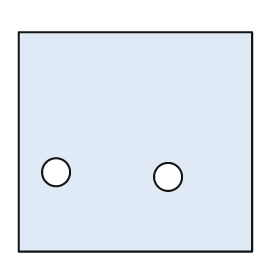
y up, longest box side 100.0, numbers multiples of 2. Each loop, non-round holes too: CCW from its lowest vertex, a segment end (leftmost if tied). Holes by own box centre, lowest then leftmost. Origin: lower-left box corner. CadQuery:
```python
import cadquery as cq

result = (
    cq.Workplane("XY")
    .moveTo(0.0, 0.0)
    .lineTo(100.0, 0.0)
    .lineTo(100.0, 94.0)
    .lineTo(0.0, 94.0)
    .close()
    .moveTo(64.0, 32.0)
    .circle(6.0)
    .moveTo(16.0, 34.0)
    .circle(6.0)
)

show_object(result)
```